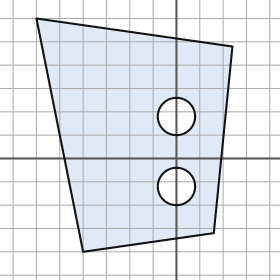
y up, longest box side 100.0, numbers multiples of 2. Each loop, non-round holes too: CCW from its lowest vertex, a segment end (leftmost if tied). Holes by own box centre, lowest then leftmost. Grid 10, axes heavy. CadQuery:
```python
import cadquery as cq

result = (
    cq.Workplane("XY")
    .moveTo(-40.0, -40.0)
    .lineTo(16.0, -32.0)
    .lineTo(24.0, 48.0)
    .lineTo(-60.0, 60.0)
    .close()
    .moveTo(0.0, -12.0)
    .circle(8.0)
    .moveTo(0.0, 18.0)
    .circle(8.0)
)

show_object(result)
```